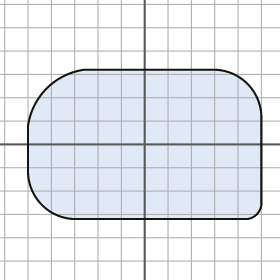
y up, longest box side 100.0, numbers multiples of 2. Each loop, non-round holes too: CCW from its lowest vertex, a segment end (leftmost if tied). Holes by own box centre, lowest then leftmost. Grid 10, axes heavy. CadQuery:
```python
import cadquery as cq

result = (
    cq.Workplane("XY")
    .moveTo(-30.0, -32.0)
    .lineTo(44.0, -32.0)
    .threePointArc((48.0, -30.0), (50.0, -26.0))
    .lineTo(50.0, 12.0)
    .threePointArc((44.0, 26.0), (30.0, 32.0))
    .lineTo(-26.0, 32.0)
    .threePointArc((-42.0, 24.0), (-50.0, 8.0))
    .lineTo(-50.0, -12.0)
    .threePointArc((-44.0, -26.0), (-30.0, -32.0))
    .close()
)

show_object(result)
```